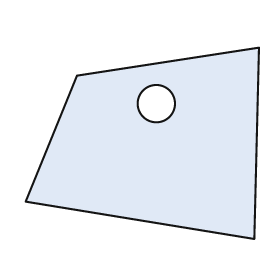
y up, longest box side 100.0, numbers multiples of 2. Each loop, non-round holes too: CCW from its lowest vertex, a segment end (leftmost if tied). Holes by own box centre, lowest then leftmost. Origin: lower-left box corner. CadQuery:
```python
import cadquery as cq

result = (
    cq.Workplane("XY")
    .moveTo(98.0, 0.0)
    .lineTo(100.0, 82.0)
    .lineTo(22.0, 70.0)
    .lineTo(0.0, 16.0)
    .close()
    .moveTo(56.0, 58.0)
    .circle(8.0)
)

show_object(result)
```